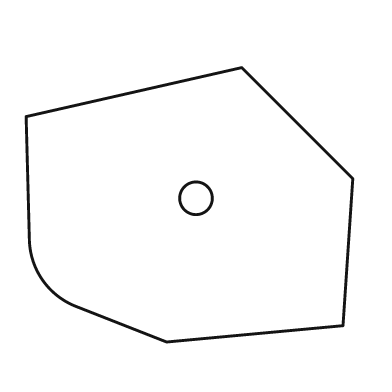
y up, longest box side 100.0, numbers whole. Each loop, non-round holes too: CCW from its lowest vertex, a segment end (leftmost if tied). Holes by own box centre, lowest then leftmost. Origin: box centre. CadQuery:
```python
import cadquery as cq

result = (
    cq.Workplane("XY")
    .moveTo(-7.0, -42.0)
    .lineTo(47.0, -37.0)
    .lineTo(50.0, 8.0)
    .lineTo(16.0, 42.0)
    .lineTo(-50.0, 27.0)
    .lineTo(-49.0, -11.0)
    .threePointArc((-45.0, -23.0), (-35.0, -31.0))
    .close()
    .moveTo(2.0, 2.0)
    .circle(5.0)
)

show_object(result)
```